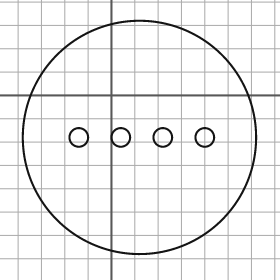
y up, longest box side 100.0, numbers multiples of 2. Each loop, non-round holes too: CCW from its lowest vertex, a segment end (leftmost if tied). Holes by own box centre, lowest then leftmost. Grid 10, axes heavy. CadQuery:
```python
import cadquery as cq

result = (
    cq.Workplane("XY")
    .moveTo(12.0, -18.0)
    .circle(50.0)
    .moveTo(-14.0, -18.0)
    .circle(4.0)
    .moveTo(4.0, -18.0)
    .circle(4.0)
    .moveTo(22.0, -18.0)
    .circle(4.0)
    .moveTo(40.0, -18.0)
    .circle(4.0)
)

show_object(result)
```